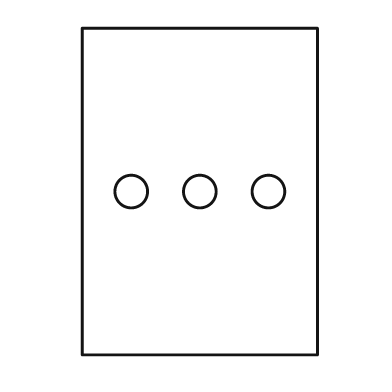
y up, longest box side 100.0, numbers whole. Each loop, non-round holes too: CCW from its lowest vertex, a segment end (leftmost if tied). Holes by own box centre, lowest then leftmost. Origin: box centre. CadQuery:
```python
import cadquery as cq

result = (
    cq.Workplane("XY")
    .moveTo(-36.0, -50.0)
    .lineTo(36.0, -50.0)
    .lineTo(36.0, 50.0)
    .lineTo(-36.0, 50.0)
    .close()
    .moveTo(-21.0, 0.0)
    .circle(5.0)
    .moveTo(0.0, 0.0)
    .circle(5.0)
    .moveTo(21.0, 0.0)
    .circle(5.0)
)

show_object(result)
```